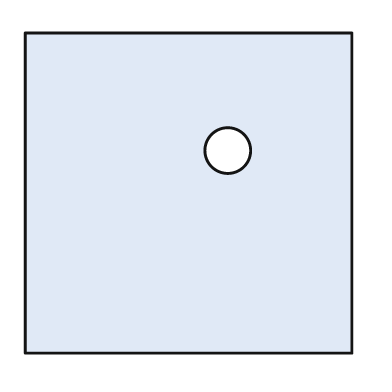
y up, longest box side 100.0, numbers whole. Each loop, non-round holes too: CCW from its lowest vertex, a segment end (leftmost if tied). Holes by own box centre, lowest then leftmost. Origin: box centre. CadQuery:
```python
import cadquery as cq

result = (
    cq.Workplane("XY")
    .moveTo(-50.0, -49.0)
    .lineTo(50.0, -49.0)
    .lineTo(50.0, 49.0)
    .lineTo(-50.0, 49.0)
    .close()
    .moveTo(12.0, 13.0)
    .circle(7.0)
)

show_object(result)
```